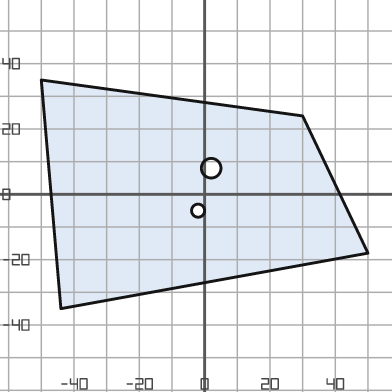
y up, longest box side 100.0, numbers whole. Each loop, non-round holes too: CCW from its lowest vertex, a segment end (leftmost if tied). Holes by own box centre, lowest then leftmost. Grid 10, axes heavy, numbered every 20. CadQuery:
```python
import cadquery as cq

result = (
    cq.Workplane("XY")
    .moveTo(-44.0, -35.0)
    .lineTo(50.0, -18.0)
    .lineTo(30.0, 24.0)
    .lineTo(-50.0, 35.0)
    .close()
    .moveTo(-2.0, -5.0)
    .circle(2.0)
    .moveTo(2.0, 8.0)
    .circle(3.0)
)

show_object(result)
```